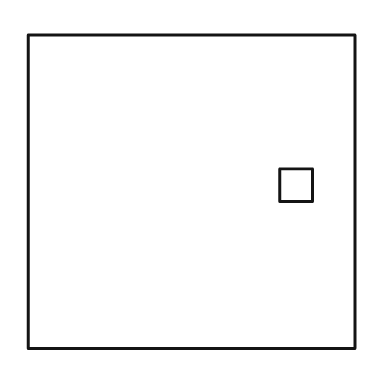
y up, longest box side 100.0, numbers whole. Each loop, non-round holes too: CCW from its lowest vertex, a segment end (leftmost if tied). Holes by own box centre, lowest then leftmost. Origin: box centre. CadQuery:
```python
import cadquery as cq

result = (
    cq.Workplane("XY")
    .moveTo(-50.0, -48.0)
    .lineTo(50.0, -48.0)
    .lineTo(50.0, 48.0)
    .lineTo(-50.0, 48.0)
    .close()
    .moveTo(27.0, -3.0)
    .lineTo(37.0, -3.0)
    .lineTo(37.0, 7.0)
    .lineTo(27.0, 7.0)
    .close()
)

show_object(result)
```